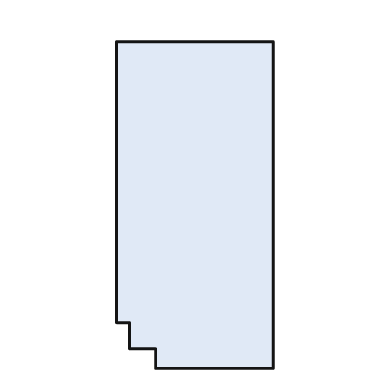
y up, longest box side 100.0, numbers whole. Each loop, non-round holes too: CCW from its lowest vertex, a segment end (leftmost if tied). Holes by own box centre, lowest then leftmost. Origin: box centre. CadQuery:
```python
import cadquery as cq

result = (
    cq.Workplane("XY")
    .moveTo(-12.0, -50.0)
    .lineTo(24.0, -50.0)
    .lineTo(24.0, 50.0)
    .lineTo(-24.0, 50.0)
    .lineTo(-24.0, -36.0)
    .lineTo(-20.0, -36.0)
    .lineTo(-20.0, -44.0)
    .lineTo(-12.0, -44.0)
    .close()
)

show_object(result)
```